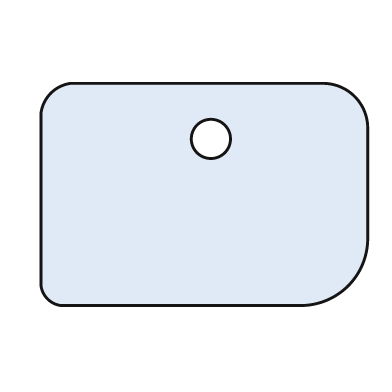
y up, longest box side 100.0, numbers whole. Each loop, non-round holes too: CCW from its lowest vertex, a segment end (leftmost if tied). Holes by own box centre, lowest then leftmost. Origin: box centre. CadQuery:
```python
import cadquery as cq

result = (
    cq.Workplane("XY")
    .moveTo(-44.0, -34.0)
    .lineTo(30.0, -34.0)
    .threePointArc((44.0, -28.0), (50.0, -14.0))
    .lineTo(50.0, 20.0)
    .threePointArc((46.0, 30.0), (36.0, 34.0))
    .lineTo(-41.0, 34.0)
    .threePointArc((-47.0, 31.0), (-50.0, 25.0))
    .lineTo(-50.0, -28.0)
    .threePointArc((-48.0, -32.0), (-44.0, -34.0))
    .close()
    .moveTo(2.0, 17.0)
    .circle(6.0)
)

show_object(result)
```